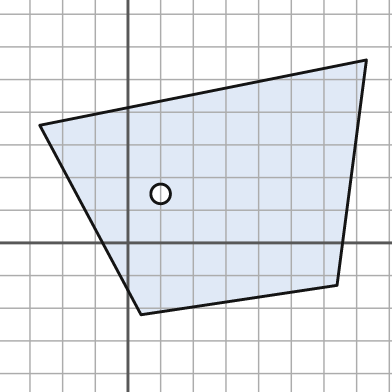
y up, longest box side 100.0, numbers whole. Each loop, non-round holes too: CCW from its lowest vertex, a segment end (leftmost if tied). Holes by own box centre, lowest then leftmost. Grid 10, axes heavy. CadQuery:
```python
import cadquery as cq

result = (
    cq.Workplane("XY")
    .moveTo(4.0, -22.0)
    .lineTo(64.0, -13.0)
    .lineTo(73.0, 56.0)
    .lineTo(-27.0, 36.0)
    .close()
    .moveTo(10.0, 15.0)
    .circle(3.0)
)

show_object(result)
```